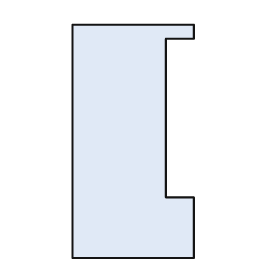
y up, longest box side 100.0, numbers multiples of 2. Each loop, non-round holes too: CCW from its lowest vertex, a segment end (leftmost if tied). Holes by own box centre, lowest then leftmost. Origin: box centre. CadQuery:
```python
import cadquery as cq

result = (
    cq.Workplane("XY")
    .moveTo(-26.0, -50.0)
    .lineTo(26.0, -50.0)
    .lineTo(26.0, -24.0)
    .lineTo(14.0, -24.0)
    .lineTo(14.0, 44.0)
    .lineTo(26.0, 44.0)
    .lineTo(26.0, 50.0)
    .lineTo(-26.0, 50.0)
    .close()
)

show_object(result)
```